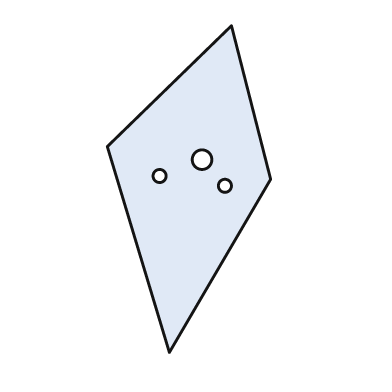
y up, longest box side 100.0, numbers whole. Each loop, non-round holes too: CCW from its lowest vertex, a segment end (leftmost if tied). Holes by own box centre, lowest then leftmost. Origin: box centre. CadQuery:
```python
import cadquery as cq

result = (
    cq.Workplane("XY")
    .moveTo(-6.0, -50.0)
    .lineTo(25.0, 3.0)
    .lineTo(13.0, 50.0)
    .lineTo(-25.0, 13.0)
    .close()
    .moveTo(11.0, 1.0)
    .circle(2.0)
    .moveTo(-9.0, 4.0)
    .circle(2.0)
    .moveTo(4.0, 9.0)
    .circle(3.0)
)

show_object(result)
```